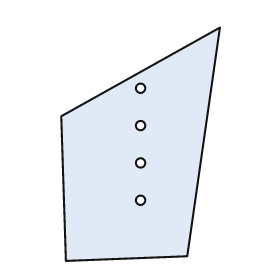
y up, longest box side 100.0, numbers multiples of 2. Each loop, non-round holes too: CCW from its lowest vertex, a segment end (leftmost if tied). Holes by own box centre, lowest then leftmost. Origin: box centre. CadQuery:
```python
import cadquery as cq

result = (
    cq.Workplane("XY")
    .moveTo(-32.0, -50.0)
    .lineTo(20.0, -48.0)
    .lineTo(34.0, 50.0)
    .lineTo(-34.0, 12.0)
    .close()
    .moveTo(0.0, -24.0)
    .circle(2.0)
    .moveTo(0.0, -8.0)
    .circle(2.0)
    .moveTo(0.0, 8.0)
    .circle(2.0)
    .moveTo(0.0, 24.0)
    .circle(2.0)
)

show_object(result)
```